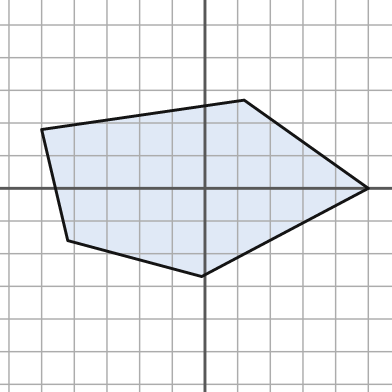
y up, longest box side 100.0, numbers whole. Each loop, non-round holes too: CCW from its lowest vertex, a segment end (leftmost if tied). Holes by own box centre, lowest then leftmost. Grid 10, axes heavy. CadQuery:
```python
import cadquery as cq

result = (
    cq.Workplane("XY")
    .moveTo(-1.0, -27.0)
    .lineTo(50.0, 0.0)
    .lineTo(12.0, 27.0)
    .lineTo(-50.0, 18.0)
    .lineTo(-42.0, -16.0)
    .close()
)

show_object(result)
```